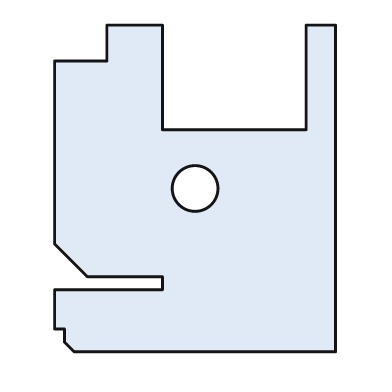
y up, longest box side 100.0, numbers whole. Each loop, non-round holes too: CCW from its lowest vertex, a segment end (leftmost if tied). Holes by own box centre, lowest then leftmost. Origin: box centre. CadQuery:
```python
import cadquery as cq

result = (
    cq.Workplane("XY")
    .moveTo(-37.0, -50.0)
    .lineTo(43.0, -50.0)
    .lineTo(43.0, 50.0)
    .lineTo(34.0, 50.0)
    .lineTo(34.0, 18.0)
    .lineTo(-10.0, 18.0)
    .lineTo(-10.0, 50.0)
    .lineTo(-27.0, 50.0)
    .lineTo(-27.0, 39.0)
    .lineTo(-43.0, 39.0)
    .lineTo(-43.0, -17.0)
    .lineTo(-33.0, -27.0)
    .lineTo(-10.0, -27.0)
    .lineTo(-10.0, -31.0)
    .lineTo(-43.0, -31.0)
    .lineTo(-43.0, -43.0)
    .lineTo(-40.0, -43.0)
    .lineTo(-40.0, -47.0)
    .close()
    .moveTo(0.0, 0.0)
    .circle(7.0)
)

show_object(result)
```